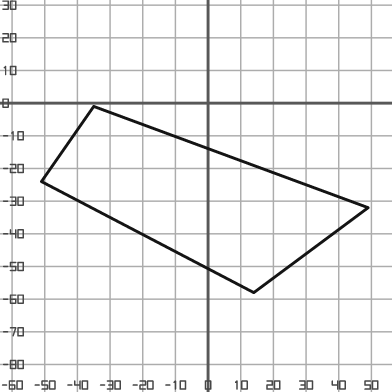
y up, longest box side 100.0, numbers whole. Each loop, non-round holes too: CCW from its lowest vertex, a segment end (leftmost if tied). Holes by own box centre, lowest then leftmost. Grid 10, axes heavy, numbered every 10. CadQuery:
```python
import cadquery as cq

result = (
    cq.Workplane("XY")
    .moveTo(14.0, -58.0)
    .lineTo(49.0, -32.0)
    .lineTo(-35.0, -1.0)
    .lineTo(-51.0, -24.0)
    .close()
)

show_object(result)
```